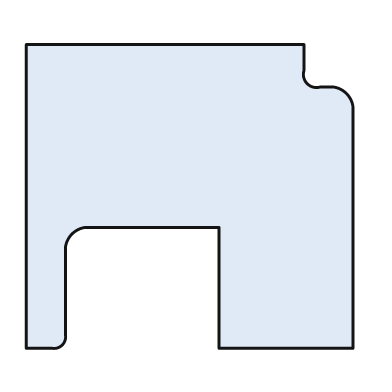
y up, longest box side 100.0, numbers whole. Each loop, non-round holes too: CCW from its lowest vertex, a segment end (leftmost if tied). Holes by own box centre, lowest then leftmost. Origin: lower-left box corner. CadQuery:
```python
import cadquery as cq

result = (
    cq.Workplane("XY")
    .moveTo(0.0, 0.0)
    .lineTo(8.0, 0.0)
    .threePointArc((11.0, 1.0), (12.0, 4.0))
    .lineTo(12.0, 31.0)
    .threePointArc((14.0, 35.0), (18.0, 37.0))
    .lineTo(59.0, 37.0)
    .lineTo(59.0, 0.0)
    .lineTo(100.0, 0.0)
    .lineTo(100.0, 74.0)
    .threePointArc((98.0, 78.0), (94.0, 80.0))
    .lineTo(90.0, 80.0)
    .threePointArc((86.0, 81.0), (85.0, 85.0))
    .lineTo(85.0, 93.0)
    .lineTo(0.0, 93.0)
    .close()
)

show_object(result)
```